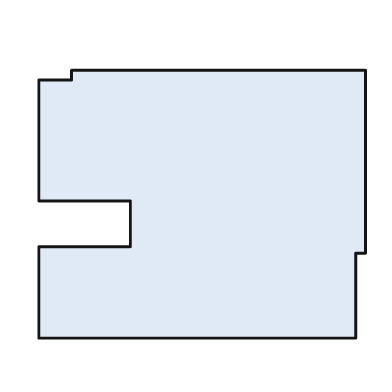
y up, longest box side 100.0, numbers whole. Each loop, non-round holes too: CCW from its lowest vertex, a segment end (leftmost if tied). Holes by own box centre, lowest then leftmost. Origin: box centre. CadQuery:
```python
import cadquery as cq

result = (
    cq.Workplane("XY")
    .moveTo(-50.0, -41.0)
    .lineTo(47.0, -41.0)
    .lineTo(47.0, -15.0)
    .lineTo(50.0, -15.0)
    .lineTo(50.0, 41.0)
    .lineTo(-40.0, 41.0)
    .lineTo(-40.0, 38.0)
    .lineTo(-50.0, 38.0)
    .lineTo(-50.0, 1.0)
    .lineTo(-22.0, 1.0)
    .lineTo(-22.0, -13.0)
    .lineTo(-50.0, -13.0)
    .close()
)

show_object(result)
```